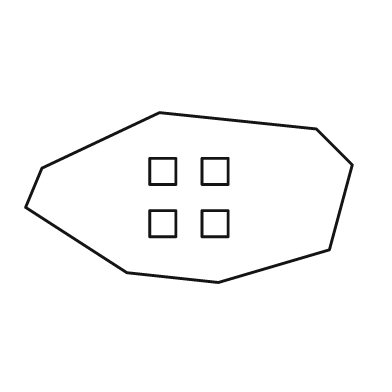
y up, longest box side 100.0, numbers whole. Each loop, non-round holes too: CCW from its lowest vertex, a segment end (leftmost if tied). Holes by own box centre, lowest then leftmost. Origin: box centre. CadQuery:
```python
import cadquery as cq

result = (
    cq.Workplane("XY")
    .moveTo(9.0, -26.0)
    .lineTo(43.0, -16.0)
    .lineTo(50.0, 10.0)
    .lineTo(39.0, 21.0)
    .lineTo(-9.0, 26.0)
    .lineTo(-45.0, 9.0)
    .lineTo(-50.0, -3.0)
    .lineTo(-19.0, -23.0)
    .close()
    .moveTo(-12.0, -12.0)
    .lineTo(-4.0, -12.0)
    .lineTo(-4.0, -4.0)
    .lineTo(-12.0, -4.0)
    .close()
    .moveTo(4.0, -12.0)
    .lineTo(12.0, -12.0)
    .lineTo(12.0, -4.0)
    .lineTo(4.0, -4.0)
    .close()
    .moveTo(-12.0, 4.0)
    .lineTo(-4.0, 4.0)
    .lineTo(-4.0, 12.0)
    .lineTo(-12.0, 12.0)
    .close()
    .moveTo(4.0, 4.0)
    .lineTo(12.0, 4.0)
    .lineTo(12.0, 12.0)
    .lineTo(4.0, 12.0)
    .close()
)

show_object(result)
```